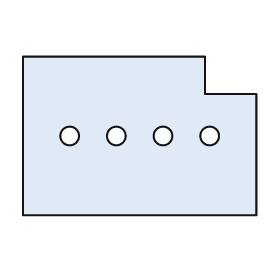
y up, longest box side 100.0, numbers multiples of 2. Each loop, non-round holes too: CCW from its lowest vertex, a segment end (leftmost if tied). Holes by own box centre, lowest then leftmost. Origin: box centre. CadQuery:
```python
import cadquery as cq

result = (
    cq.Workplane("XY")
    .moveTo(-50.0, -34.0)
    .lineTo(50.0, -34.0)
    .lineTo(50.0, 18.0)
    .lineTo(28.0, 18.0)
    .lineTo(28.0, 34.0)
    .lineTo(-50.0, 34.0)
    .close()
    .moveTo(-30.0, 0.0)
    .circle(4.0)
    .moveTo(-10.0, 0.0)
    .circle(4.0)
    .moveTo(10.0, 0.0)
    .circle(4.0)
    .moveTo(30.0, 0.0)
    .circle(4.0)
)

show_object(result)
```